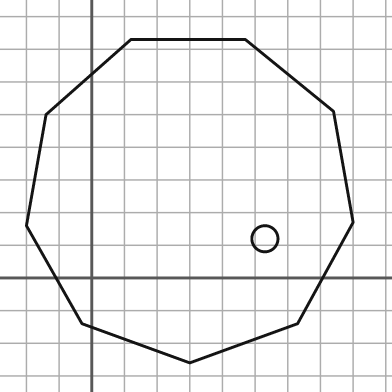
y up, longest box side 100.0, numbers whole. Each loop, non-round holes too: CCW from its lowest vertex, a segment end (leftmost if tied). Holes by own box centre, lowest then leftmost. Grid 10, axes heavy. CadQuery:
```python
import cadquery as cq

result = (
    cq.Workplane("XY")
    .moveTo(30.0, -26.0)
    .lineTo(63.0, -14.0)
    .lineTo(80.0, 17.0)
    .lineTo(74.0, 51.0)
    .lineTo(47.0, 73.0)
    .lineTo(12.0, 73.0)
    .lineTo(-14.0, 50.0)
    .lineTo(-20.0, 16.0)
    .lineTo(-3.0, -14.0)
    .close()
    .moveTo(53.0, 12.0)
    .circle(4.0)
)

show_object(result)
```